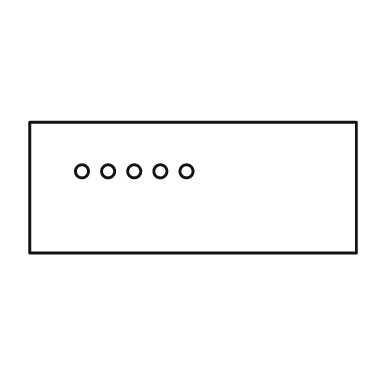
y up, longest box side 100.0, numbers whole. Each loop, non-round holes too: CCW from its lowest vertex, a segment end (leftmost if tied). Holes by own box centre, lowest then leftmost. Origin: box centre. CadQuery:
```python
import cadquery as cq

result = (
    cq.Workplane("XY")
    .moveTo(-50.0, -20.0)
    .lineTo(50.0, -20.0)
    .lineTo(50.0, 20.0)
    .lineTo(-50.0, 20.0)
    .close()
    .moveTo(-34.0, 5.0)
    .circle(2.0)
    .moveTo(-26.0, 5.0)
    .circle(2.0)
    .moveTo(-18.0, 5.0)
    .circle(2.0)
    .moveTo(-10.0, 5.0)
    .circle(2.0)
    .moveTo(-2.0, 5.0)
    .circle(2.0)
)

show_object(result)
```